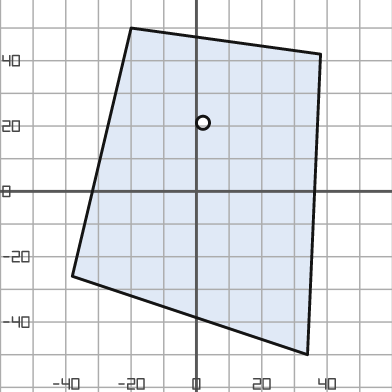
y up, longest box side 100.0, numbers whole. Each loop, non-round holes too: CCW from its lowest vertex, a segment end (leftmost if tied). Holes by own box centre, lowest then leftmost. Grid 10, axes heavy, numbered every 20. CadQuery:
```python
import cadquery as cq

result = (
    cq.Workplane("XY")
    .moveTo(34.0, -50.0)
    .lineTo(38.0, 42.0)
    .lineTo(-20.0, 50.0)
    .lineTo(-38.0, -26.0)
    .close()
    .moveTo(2.0, 21.0)
    .circle(2.0)
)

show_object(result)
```